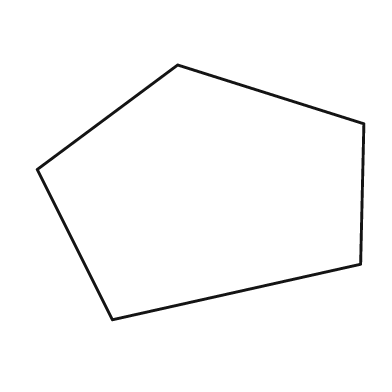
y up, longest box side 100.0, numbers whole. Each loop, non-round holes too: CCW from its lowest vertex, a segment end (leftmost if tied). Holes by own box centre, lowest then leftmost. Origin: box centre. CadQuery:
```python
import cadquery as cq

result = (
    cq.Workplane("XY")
    .moveTo(-27.0, -39.0)
    .lineTo(49.0, -22.0)
    .lineTo(50.0, 21.0)
    .lineTo(-7.0, 39.0)
    .lineTo(-50.0, 7.0)
    .close()
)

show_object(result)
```